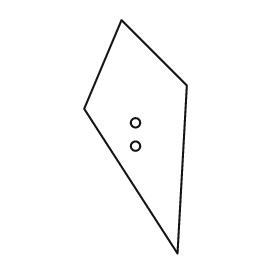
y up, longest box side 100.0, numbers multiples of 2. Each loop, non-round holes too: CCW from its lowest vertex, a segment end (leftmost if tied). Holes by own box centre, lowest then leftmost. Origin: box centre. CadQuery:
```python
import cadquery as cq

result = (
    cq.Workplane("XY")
    .moveTo(18.0, -50.0)
    .lineTo(22.0, 22.0)
    .lineTo(-6.0, 50.0)
    .lineTo(-22.0, 12.0)
    .close()
    .moveTo(0.0, -4.0)
    .circle(2.0)
    .moveTo(0.0, 6.0)
    .circle(2.0)
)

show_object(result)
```